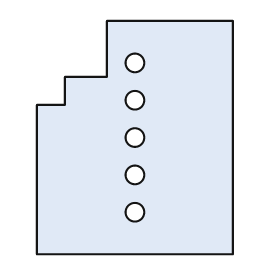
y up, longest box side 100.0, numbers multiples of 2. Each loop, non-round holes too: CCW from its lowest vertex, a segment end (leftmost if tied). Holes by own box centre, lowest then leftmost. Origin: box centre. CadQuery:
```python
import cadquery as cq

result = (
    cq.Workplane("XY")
    .moveTo(-42.0, -50.0)
    .lineTo(42.0, -50.0)
    .lineTo(42.0, 50.0)
    .lineTo(-12.0, 50.0)
    .lineTo(-12.0, 26.0)
    .lineTo(-30.0, 26.0)
    .lineTo(-30.0, 14.0)
    .lineTo(-42.0, 14.0)
    .close()
    .moveTo(0.0, -32.0)
    .circle(4.0)
    .moveTo(0.0, -16.0)
    .circle(4.0)
    .moveTo(0.0, 0.0)
    .circle(4.0)
    .moveTo(0.0, 16.0)
    .circle(4.0)
    .moveTo(0.0, 32.0)
    .circle(4.0)
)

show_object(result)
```